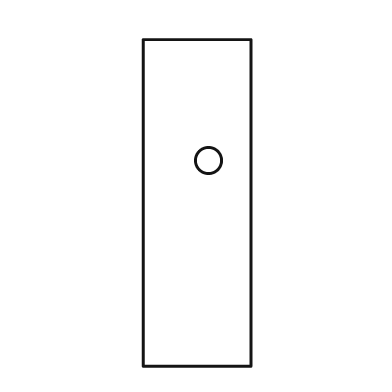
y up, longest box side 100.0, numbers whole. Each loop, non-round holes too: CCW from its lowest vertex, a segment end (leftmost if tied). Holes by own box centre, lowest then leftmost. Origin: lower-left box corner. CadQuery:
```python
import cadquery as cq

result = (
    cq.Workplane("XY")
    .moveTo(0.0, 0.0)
    .lineTo(33.0, 0.0)
    .lineTo(33.0, 100.0)
    .lineTo(0.0, 100.0)
    .close()
    .moveTo(20.0, 63.0)
    .circle(4.0)
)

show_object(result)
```